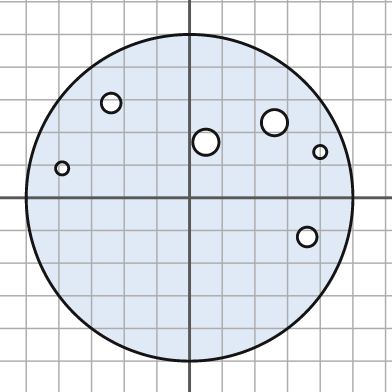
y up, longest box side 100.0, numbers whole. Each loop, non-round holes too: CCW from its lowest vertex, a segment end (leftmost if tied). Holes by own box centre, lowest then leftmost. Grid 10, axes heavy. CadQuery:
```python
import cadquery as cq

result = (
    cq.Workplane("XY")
    .moveTo(0.0, 0.0)
    .circle(50.0)
    .moveTo(36.0, -12.0)
    .circle(3.0)
    .moveTo(-39.0, 9.0)
    .circle(2.0)
    .moveTo(40.0, 14.0)
    .circle(2.0)
    .moveTo(5.0, 17.0)
    .circle(4.0)
    .moveTo(26.0, 23.0)
    .circle(4.0)
    .moveTo(-24.0, 29.0)
    .circle(3.0)
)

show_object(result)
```